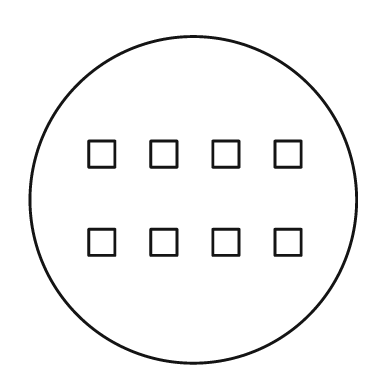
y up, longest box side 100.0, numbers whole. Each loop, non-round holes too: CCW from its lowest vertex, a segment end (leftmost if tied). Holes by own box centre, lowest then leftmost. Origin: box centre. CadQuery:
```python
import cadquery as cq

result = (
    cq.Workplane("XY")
    .moveTo(0.0, 0.0)
    .circle(50.0)
    .moveTo(-32.0, -17.0)
    .lineTo(-24.0, -17.0)
    .lineTo(-24.0, -9.0)
    .lineTo(-32.0, -9.0)
    .close()
    .moveTo(-13.0, -17.0)
    .lineTo(-5.0, -17.0)
    .lineTo(-5.0, -9.0)
    .lineTo(-13.0, -9.0)
    .close()
    .moveTo(6.0, -17.0)
    .lineTo(14.0, -17.0)
    .lineTo(14.0, -9.0)
    .lineTo(6.0, -9.0)
    .close()
    .moveTo(25.0, -17.0)
    .lineTo(33.0, -17.0)
    .lineTo(33.0, -9.0)
    .lineTo(25.0, -9.0)
    .close()
    .moveTo(-32.0, 10.0)
    .lineTo(-24.0, 10.0)
    .lineTo(-24.0, 18.0)
    .lineTo(-32.0, 18.0)
    .close()
    .moveTo(-13.0, 10.0)
    .lineTo(-5.0, 10.0)
    .lineTo(-5.0, 18.0)
    .lineTo(-13.0, 18.0)
    .close()
    .moveTo(6.0, 10.0)
    .lineTo(14.0, 10.0)
    .lineTo(14.0, 18.0)
    .lineTo(6.0, 18.0)
    .close()
    .moveTo(25.0, 10.0)
    .lineTo(33.0, 10.0)
    .lineTo(33.0, 18.0)
    .lineTo(25.0, 18.0)
    .close()
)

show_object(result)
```